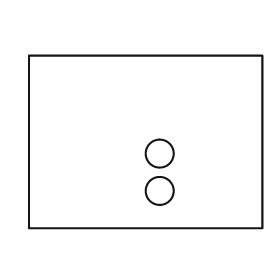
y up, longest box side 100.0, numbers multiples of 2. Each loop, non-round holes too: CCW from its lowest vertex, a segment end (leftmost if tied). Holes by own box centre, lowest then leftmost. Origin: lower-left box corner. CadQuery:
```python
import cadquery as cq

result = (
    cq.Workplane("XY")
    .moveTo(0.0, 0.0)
    .lineTo(100.0, 0.0)
    .lineTo(100.0, 74.0)
    .lineTo(0.0, 74.0)
    .close()
    .moveTo(56.0, 16.0)
    .circle(6.0)
    .moveTo(56.0, 32.0)
    .circle(6.0)
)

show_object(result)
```